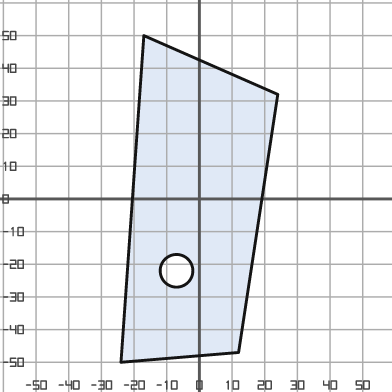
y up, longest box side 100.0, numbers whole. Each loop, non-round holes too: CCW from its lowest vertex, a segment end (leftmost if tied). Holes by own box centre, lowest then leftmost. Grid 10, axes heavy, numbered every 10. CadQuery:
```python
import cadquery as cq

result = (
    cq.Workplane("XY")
    .moveTo(-24.0, -50.0)
    .lineTo(12.0, -47.0)
    .lineTo(24.0, 32.0)
    .lineTo(-17.0, 50.0)
    .close()
    .moveTo(-7.0, -22.0)
    .circle(5.0)
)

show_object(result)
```